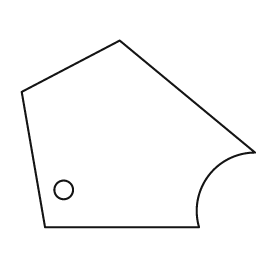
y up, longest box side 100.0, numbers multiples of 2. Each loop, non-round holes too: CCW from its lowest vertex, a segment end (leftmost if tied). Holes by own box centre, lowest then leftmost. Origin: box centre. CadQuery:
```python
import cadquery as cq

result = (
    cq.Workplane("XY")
    .moveTo(-40.0, -40.0)
    .lineTo(26.0, -40.0)
    .threePointArc((30.0, -18.0), (50.0, -8.0))
    .lineTo(-8.0, 40.0)
    .lineTo(-50.0, 18.0)
    .close()
    .moveTo(-32.0, -24.0)
    .circle(4.0)
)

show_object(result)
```